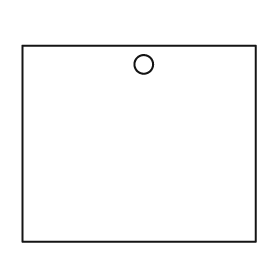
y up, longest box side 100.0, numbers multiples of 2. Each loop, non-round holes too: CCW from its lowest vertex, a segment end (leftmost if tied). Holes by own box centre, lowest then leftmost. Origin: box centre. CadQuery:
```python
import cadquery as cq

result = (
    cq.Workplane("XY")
    .moveTo(-50.0, -42.0)
    .lineTo(50.0, -42.0)
    .lineTo(50.0, 42.0)
    .lineTo(-50.0, 42.0)
    .close()
    .moveTo(2.0, 34.0)
    .circle(4.0)
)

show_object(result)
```